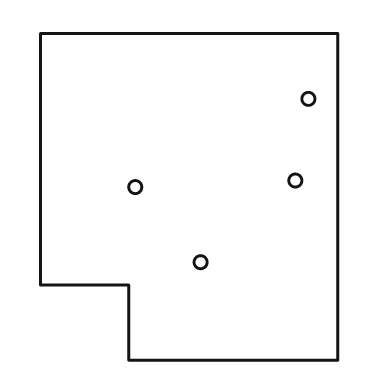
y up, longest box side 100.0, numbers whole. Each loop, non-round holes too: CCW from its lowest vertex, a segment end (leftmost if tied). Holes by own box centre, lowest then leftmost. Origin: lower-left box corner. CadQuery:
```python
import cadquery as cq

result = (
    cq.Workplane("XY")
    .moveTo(27.0, 0.0)
    .lineTo(91.0, 0.0)
    .lineTo(91.0, 100.0)
    .lineTo(0.0, 100.0)
    .lineTo(0.0, 23.0)
    .lineTo(27.0, 23.0)
    .close()
    .moveTo(49.0, 30.0)
    .circle(2.0)
    .moveTo(29.0, 53.0)
    .circle(2.0)
    .moveTo(78.0, 55.0)
    .circle(2.0)
    .moveTo(82.0, 80.0)
    .circle(2.0)
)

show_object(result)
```